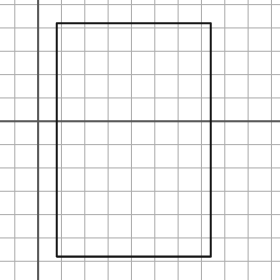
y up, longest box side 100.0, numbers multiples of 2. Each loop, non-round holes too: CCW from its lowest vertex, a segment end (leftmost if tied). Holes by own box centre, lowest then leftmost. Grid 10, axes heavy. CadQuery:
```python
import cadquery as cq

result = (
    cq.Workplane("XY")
    .moveTo(8.0, -58.0)
    .lineTo(74.0, -58.0)
    .lineTo(74.0, 42.0)
    .lineTo(8.0, 42.0)
    .close()
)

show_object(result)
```